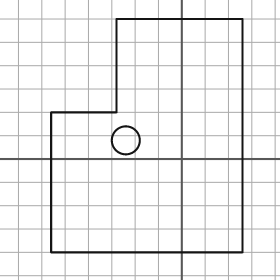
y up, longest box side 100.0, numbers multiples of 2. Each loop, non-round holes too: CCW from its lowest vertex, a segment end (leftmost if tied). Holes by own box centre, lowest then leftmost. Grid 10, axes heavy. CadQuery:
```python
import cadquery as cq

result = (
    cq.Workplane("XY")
    .moveTo(-56.0, -40.0)
    .lineTo(26.0, -40.0)
    .lineTo(26.0, 60.0)
    .lineTo(-28.0, 60.0)
    .lineTo(-28.0, 20.0)
    .lineTo(-56.0, 20.0)
    .close()
    .moveTo(-24.0, 8.0)
    .circle(6.0)
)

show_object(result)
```